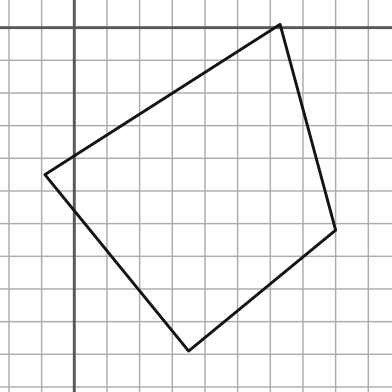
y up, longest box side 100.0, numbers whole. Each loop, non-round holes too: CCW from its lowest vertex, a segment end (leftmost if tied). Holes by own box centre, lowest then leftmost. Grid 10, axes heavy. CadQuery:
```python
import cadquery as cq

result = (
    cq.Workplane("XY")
    .moveTo(35.0, -99.0)
    .lineTo(80.0, -62.0)
    .lineTo(63.0, 1.0)
    .lineTo(-9.0, -45.0)
    .close()
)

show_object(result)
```